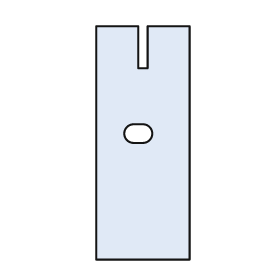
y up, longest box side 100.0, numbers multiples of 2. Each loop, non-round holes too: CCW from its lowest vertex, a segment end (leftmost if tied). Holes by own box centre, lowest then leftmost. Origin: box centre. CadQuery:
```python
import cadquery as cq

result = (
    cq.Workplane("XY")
    .moveTo(-20.0, -50.0)
    .lineTo(20.0, -50.0)
    .lineTo(20.0, 50.0)
    .lineTo(2.0, 50.0)
    .lineTo(2.0, 32.0)
    .lineTo(-2.0, 32.0)
    .lineTo(-2.0, 50.0)
    .lineTo(-20.0, 50.0)
    .close()
    .moveTo(-4.0, 0.0)
    .lineTo(0.0, 0.0)
    .threePointArc((4.0, 4.0), (0.0, 8.0))
    .lineTo(-4.0, 8.0)
    .threePointArc((-8.0, 4.0), (-4.0, 0.0))
    .close()
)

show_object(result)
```